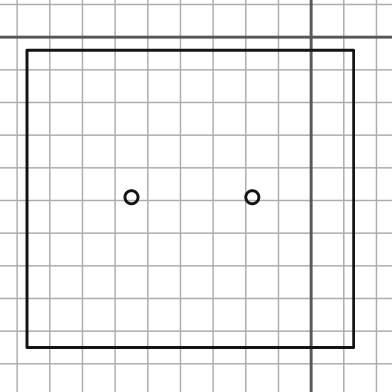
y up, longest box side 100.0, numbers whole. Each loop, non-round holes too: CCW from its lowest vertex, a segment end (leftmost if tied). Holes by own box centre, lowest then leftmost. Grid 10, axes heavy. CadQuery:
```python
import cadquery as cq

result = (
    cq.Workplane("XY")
    .moveTo(-87.0, -95.0)
    .lineTo(13.0, -95.0)
    .lineTo(13.0, -4.0)
    .lineTo(-87.0, -4.0)
    .close()
    .moveTo(-55.0, -49.0)
    .circle(2.0)
    .moveTo(-18.0, -49.0)
    .circle(2.0)
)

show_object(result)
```